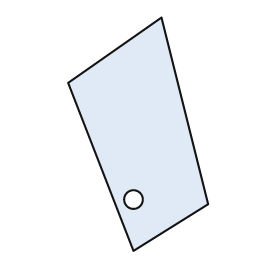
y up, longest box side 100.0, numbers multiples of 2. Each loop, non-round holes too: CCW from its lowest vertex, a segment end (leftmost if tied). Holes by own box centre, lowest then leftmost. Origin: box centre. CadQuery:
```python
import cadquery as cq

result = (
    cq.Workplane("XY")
    .moveTo(-2.0, -50.0)
    .lineTo(30.0, -30.0)
    .lineTo(10.0, 50.0)
    .lineTo(-30.0, 22.0)
    .close()
    .moveTo(-2.0, -28.0)
    .circle(4.0)
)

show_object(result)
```